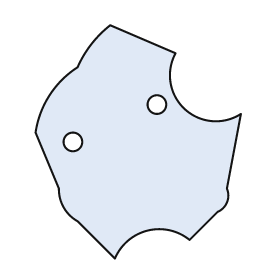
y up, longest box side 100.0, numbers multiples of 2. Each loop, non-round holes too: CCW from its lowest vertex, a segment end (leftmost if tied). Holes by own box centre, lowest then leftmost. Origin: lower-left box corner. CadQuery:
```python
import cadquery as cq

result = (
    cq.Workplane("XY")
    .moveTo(34.0, 0.0)
    .threePointArc((48.0, 12.0), (66.0, 8.0))
    .lineTo(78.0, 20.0)
    .threePointArc((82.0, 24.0), (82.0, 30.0))
    .lineTo(88.0, 62.0)
    .threePointArc((64.0, 64.0), (60.0, 88.0))
    .lineTo(32.0, 100.0)
    .threePointArc((24.0, 92.0), (18.0, 82.0))
    .threePointArc((6.0, 70.0), (0.0, 54.0))
    .lineTo(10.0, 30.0)
    .threePointArc((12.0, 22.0), (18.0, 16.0))
    .close()
    .moveTo(16.0, 50.0)
    .circle(4.0)
    .moveTo(52.0, 66.0)
    .circle(4.0)
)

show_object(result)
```